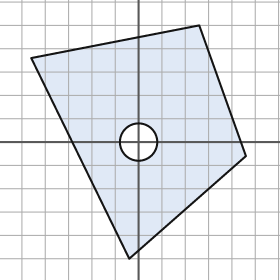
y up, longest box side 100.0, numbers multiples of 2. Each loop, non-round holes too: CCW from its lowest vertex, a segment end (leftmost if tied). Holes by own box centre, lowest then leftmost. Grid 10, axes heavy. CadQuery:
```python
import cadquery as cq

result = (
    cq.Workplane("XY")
    .moveTo(-4.0, -50.0)
    .lineTo(46.0, -6.0)
    .lineTo(26.0, 50.0)
    .lineTo(-46.0, 36.0)
    .close()
    .moveTo(0.0, 0.0)
    .circle(8.0)
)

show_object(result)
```